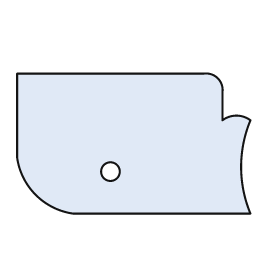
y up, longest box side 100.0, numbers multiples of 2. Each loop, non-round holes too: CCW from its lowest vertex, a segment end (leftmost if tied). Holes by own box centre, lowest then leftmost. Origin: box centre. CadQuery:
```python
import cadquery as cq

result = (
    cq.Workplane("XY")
    .moveTo(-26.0, -30.0)
    .lineTo(50.0, -30.0)
    .threePointArc((46.0, -10.0), (50.0, 10.0))
    .threePointArc((44.0, 12.0), (38.0, 10.0))
    .lineTo(38.0, 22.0)
    .threePointArc((36.0, 28.0), (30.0, 30.0))
    .lineTo(-50.0, 30.0)
    .lineTo(-50.0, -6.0)
    .threePointArc((-42.0, -22.0), (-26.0, -30.0))
    .close()
    .moveTo(-10.0, -12.0)
    .circle(4.0)
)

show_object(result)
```